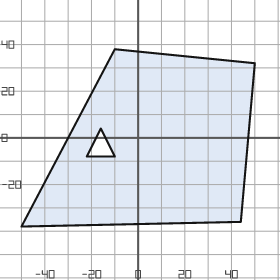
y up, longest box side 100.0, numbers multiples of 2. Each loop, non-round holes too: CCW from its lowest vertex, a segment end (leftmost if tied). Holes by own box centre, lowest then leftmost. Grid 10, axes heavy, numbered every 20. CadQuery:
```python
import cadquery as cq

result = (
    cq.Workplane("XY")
    .moveTo(-50.0, -38.0)
    .lineTo(44.0, -36.0)
    .lineTo(50.0, 32.0)
    .lineTo(-10.0, 38.0)
    .close()
    .moveTo(-22.0, -8.0)
    .lineTo(-10.0, -8.0)
    .lineTo(-16.0, 4.0)
    .close()
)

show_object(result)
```